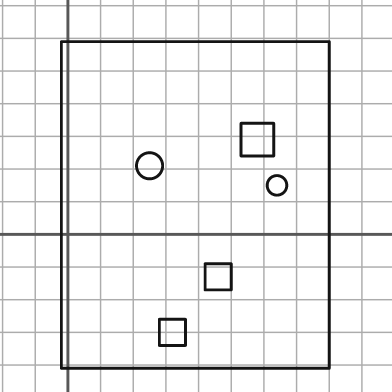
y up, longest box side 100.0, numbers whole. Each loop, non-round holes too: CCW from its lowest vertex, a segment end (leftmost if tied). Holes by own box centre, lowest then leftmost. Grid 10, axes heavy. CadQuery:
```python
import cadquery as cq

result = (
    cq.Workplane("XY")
    .moveTo(-2.0, -41.0)
    .lineTo(80.0, -41.0)
    .lineTo(80.0, 59.0)
    .lineTo(-2.0, 59.0)
    .close()
    .moveTo(28.0, -34.0)
    .lineTo(36.0, -34.0)
    .lineTo(36.0, -26.0)
    .lineTo(28.0, -26.0)
    .close()
    .moveTo(42.0, -17.0)
    .lineTo(50.0, -17.0)
    .lineTo(50.0, -9.0)
    .lineTo(42.0, -9.0)
    .close()
    .moveTo(64.0, 15.0)
    .circle(3.0)
    .moveTo(25.0, 21.0)
    .circle(4.0)
    .moveTo(53.0, 24.0)
    .lineTo(63.0, 24.0)
    .lineTo(63.0, 34.0)
    .lineTo(53.0, 34.0)
    .close()
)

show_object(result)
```